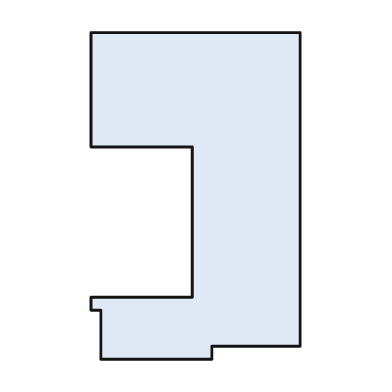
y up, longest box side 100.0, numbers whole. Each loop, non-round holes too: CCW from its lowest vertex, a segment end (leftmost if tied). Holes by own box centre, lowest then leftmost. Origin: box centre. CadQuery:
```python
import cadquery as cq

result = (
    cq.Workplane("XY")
    .moveTo(-29.0, -50.0)
    .lineTo(5.0, -50.0)
    .lineTo(5.0, -46.0)
    .lineTo(32.0, -46.0)
    .lineTo(32.0, 50.0)
    .lineTo(-32.0, 50.0)
    .lineTo(-32.0, 15.0)
    .lineTo(-1.0, 15.0)
    .lineTo(-1.0, -31.0)
    .lineTo(-32.0, -31.0)
    .lineTo(-32.0, -35.0)
    .lineTo(-29.0, -35.0)
    .close()
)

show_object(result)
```